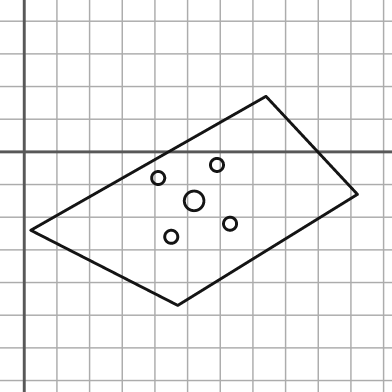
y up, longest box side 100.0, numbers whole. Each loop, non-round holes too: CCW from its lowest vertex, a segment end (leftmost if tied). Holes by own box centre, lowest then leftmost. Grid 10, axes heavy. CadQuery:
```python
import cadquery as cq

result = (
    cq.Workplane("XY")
    .moveTo(47.0, -47.0)
    .lineTo(102.0, -13.0)
    .lineTo(74.0, 17.0)
    .lineTo(2.0, -24.0)
    .close()
    .moveTo(45.0, -26.0)
    .circle(2.0)
    .moveTo(63.0, -22.0)
    .circle(2.0)
    .moveTo(52.0, -15.0)
    .circle(3.0)
    .moveTo(41.0, -8.0)
    .circle(2.0)
    .moveTo(59.0, -4.0)
    .circle(2.0)
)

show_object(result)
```